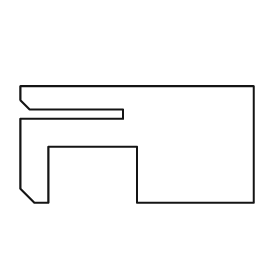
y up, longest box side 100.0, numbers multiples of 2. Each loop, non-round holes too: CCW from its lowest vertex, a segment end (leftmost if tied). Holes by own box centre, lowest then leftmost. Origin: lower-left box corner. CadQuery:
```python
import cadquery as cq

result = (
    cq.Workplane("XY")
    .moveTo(6.0, 0.0)
    .lineTo(12.0, 0.0)
    .lineTo(12.0, 24.0)
    .lineTo(50.0, 24.0)
    .lineTo(50.0, 0.0)
    .lineTo(100.0, 0.0)
    .lineTo(100.0, 50.0)
    .lineTo(0.0, 50.0)
    .lineTo(0.0, 44.0)
    .lineTo(4.0, 40.0)
    .lineTo(44.0, 40.0)
    .lineTo(44.0, 36.0)
    .lineTo(0.0, 36.0)
    .lineTo(0.0, 6.0)
    .close()
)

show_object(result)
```